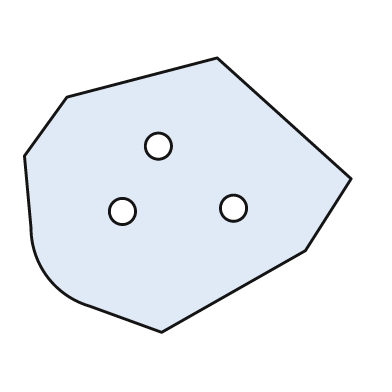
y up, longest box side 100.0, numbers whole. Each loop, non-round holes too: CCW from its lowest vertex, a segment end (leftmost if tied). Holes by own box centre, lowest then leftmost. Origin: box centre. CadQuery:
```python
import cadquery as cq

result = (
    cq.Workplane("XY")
    .moveTo(-8.0, -42.0)
    .lineTo(36.0, -17.0)
    .lineTo(50.0, 5.0)
    .lineTo(9.0, 42.0)
    .lineTo(-37.0, 30.0)
    .lineTo(-50.0, 12.0)
    .lineTo(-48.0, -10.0)
    .threePointArc((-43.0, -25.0), (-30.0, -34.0))
    .close()
    .moveTo(-20.0, -5.0)
    .circle(4.0)
    .moveTo(14.0, -4.0)
    .circle(4.0)
    .moveTo(-9.0, 15.0)
    .circle(4.0)
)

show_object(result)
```